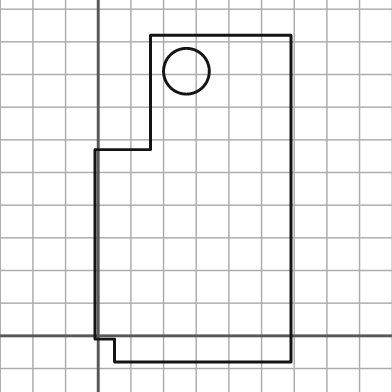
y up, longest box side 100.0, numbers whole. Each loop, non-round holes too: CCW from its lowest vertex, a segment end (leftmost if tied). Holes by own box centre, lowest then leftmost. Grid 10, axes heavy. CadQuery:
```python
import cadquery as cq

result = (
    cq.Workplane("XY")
    .moveTo(5.0, -8.0)
    .lineTo(59.0, -8.0)
    .lineTo(59.0, 92.0)
    .lineTo(16.0, 92.0)
    .lineTo(16.0, 57.0)
    .lineTo(-1.0, 57.0)
    .lineTo(-1.0, -1.0)
    .lineTo(5.0, -1.0)
    .close()
    .moveTo(27.0, 81.0)
    .circle(7.0)
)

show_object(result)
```